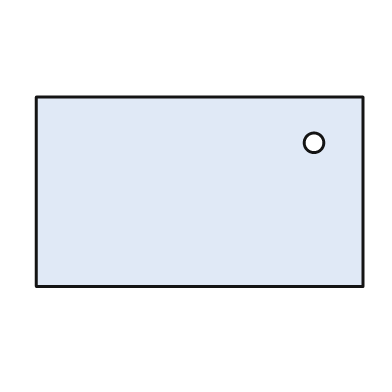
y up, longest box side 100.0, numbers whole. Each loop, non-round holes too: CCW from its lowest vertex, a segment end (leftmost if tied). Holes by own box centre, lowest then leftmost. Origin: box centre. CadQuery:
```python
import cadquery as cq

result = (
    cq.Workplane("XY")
    .moveTo(-50.0, -29.0)
    .lineTo(50.0, -29.0)
    .lineTo(50.0, 29.0)
    .lineTo(-50.0, 29.0)
    .close()
    .moveTo(35.0, 15.0)
    .circle(3.0)
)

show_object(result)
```